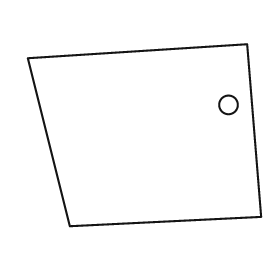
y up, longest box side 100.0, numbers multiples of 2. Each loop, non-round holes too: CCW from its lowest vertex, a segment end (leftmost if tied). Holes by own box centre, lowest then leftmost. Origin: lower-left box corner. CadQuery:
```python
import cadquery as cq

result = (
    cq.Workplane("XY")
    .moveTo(18.0, 0.0)
    .lineTo(100.0, 4.0)
    .lineTo(94.0, 78.0)
    .lineTo(0.0, 72.0)
    .close()
    .moveTo(86.0, 52.0)
    .circle(4.0)
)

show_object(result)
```